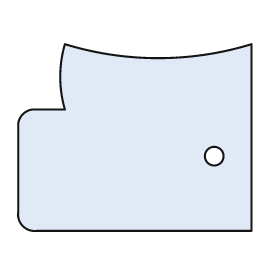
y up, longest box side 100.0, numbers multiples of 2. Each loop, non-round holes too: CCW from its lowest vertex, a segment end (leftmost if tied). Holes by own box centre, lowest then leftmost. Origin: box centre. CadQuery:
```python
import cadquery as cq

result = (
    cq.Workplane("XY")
    .moveTo(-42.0, -40.0)
    .lineTo(50.0, -40.0)
    .lineTo(50.0, 40.0)
    .threePointArc((10.0, 34.0), (-30.0, 40.0))
    .threePointArc((-32.0, 26.0), (-30.0, 12.0))
    .lineTo(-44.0, 12.0)
    .threePointArc((-48.0, 10.0), (-50.0, 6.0))
    .lineTo(-50.0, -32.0)
    .threePointArc((-48.0, -38.0), (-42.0, -40.0))
    .close()
    .moveTo(34.0, -8.0)
    .circle(4.0)
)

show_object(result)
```